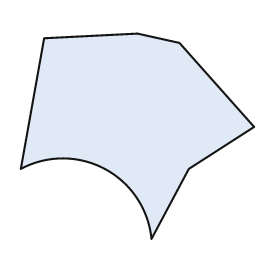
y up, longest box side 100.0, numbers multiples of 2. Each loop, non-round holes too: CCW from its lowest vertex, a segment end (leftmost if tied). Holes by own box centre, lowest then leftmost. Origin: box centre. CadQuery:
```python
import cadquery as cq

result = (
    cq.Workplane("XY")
    .moveTo(6.0, -44.0)
    .lineTo(22.0, -14.0)
    .lineTo(50.0, 4.0)
    .lineTo(18.0, 40.0)
    .lineTo(0.0, 44.0)
    .lineTo(-40.0, 42.0)
    .lineTo(-50.0, -14.0)
    .threePointArc((-14.0, -14.0), (6.0, -44.0))
    .close()
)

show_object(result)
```